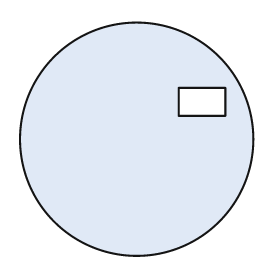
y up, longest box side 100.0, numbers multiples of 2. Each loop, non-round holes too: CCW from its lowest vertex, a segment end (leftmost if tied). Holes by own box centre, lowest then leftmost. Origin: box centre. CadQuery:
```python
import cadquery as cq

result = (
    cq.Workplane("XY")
    .moveTo(0.0, 0.0)
    .circle(50.0)
    .moveTo(18.0, 10.0)
    .lineTo(38.0, 10.0)
    .lineTo(38.0, 22.0)
    .lineTo(18.0, 22.0)
    .close()
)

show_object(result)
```